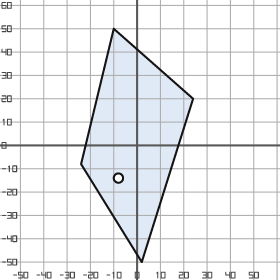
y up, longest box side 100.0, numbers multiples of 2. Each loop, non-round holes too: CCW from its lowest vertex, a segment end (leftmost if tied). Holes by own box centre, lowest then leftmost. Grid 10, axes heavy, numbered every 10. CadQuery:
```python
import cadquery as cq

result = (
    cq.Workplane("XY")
    .moveTo(2.0, -50.0)
    .lineTo(24.0, 20.0)
    .lineTo(-10.0, 50.0)
    .lineTo(-24.0, -8.0)
    .close()
    .moveTo(-8.0, -14.0)
    .circle(2.0)
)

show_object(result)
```